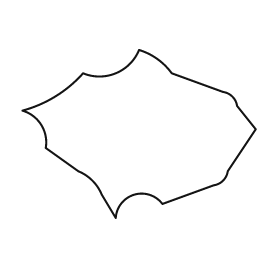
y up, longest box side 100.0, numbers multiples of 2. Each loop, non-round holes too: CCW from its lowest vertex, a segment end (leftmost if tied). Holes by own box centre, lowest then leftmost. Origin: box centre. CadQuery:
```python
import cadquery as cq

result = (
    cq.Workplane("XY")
    .moveTo(-10.0, -36.0)
    .threePointArc((-2.0, -26.0), (10.0, -30.0))
    .lineTo(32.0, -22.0)
    .threePointArc((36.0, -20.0), (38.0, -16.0))
    .lineTo(50.0, 2.0)
    .lineTo(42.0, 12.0)
    .threePointArc((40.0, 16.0), (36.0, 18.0))
    .lineTo(14.0, 26.0)
    .threePointArc((8.0, 32.0), (0.0, 36.0))
    .threePointArc((-10.0, 26.0), (-24.0, 26.0))
    .threePointArc((-36.0, 16.0), (-50.0, 10.0))
    .threePointArc((-42.0, 4.0), (-40.0, -6.0))
    .lineTo(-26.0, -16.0)
    .threePointArc((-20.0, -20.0), (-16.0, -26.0))
    .close()
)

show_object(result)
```